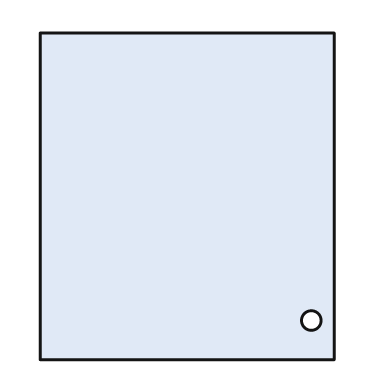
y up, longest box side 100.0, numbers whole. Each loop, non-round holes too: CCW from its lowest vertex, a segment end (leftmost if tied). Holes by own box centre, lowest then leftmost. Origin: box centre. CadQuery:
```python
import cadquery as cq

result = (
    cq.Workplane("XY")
    .moveTo(-45.0, -50.0)
    .lineTo(45.0, -50.0)
    .lineTo(45.0, 50.0)
    .lineTo(-45.0, 50.0)
    .close()
    .moveTo(38.0, -38.0)
    .circle(3.0)
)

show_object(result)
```